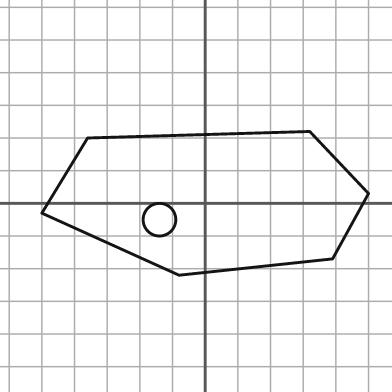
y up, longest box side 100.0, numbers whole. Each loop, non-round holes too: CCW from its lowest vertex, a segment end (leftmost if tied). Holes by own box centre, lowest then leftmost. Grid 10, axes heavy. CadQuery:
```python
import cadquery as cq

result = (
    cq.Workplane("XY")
    .moveTo(-8.0, -22.0)
    .lineTo(39.0, -17.0)
    .lineTo(50.0, 3.0)
    .lineTo(32.0, 22.0)
    .lineTo(-36.0, 20.0)
    .lineTo(-50.0, -3.0)
    .close()
    .moveTo(-14.0, -5.0)
    .circle(5.0)
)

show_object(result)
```